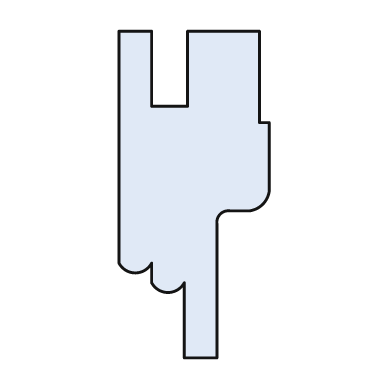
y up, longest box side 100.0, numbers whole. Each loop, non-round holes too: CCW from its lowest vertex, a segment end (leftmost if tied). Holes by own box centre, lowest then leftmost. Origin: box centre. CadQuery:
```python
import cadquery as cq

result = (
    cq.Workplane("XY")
    .moveTo(-3.0, -50.0)
    .lineTo(7.0, -50.0)
    .lineTo(7.0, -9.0)
    .threePointArc((8.0, -6.0), (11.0, -5.0))
    .lineTo(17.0, -5.0)
    .threePointArc((21.0, -3.0), (23.0, 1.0))
    .lineTo(23.0, 22.0)
    .lineTo(20.0, 22.0)
    .lineTo(20.0, 50.0)
    .lineTo(-2.0, 50.0)
    .lineTo(-2.0, 27.0)
    .lineTo(-13.0, 27.0)
    .lineTo(-13.0, 50.0)
    .lineTo(-23.0, 50.0)
    .lineTo(-23.0, -21.0)
    .threePointArc((-18.0, -24.0), (-13.0, -21.0))
    .lineTo(-13.0, -27.0)
    .threePointArc((-8.0, -30.0), (-3.0, -27.0))
    .close()
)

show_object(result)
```